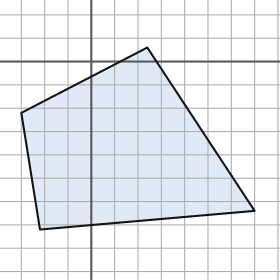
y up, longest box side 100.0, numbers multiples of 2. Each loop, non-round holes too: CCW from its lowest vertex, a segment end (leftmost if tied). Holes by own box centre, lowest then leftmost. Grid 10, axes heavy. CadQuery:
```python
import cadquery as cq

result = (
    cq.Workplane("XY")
    .moveTo(-22.0, -72.0)
    .lineTo(70.0, -64.0)
    .lineTo(24.0, 6.0)
    .lineTo(-30.0, -22.0)
    .close()
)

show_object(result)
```